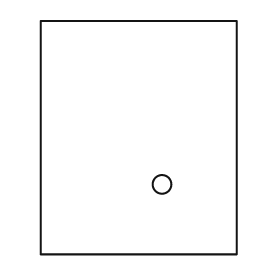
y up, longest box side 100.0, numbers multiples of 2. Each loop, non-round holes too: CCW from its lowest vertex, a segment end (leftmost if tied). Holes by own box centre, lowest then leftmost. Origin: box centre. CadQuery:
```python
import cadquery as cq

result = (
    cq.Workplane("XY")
    .moveTo(-42.0, -50.0)
    .lineTo(42.0, -50.0)
    .lineTo(42.0, 50.0)
    .lineTo(-42.0, 50.0)
    .close()
    .moveTo(10.0, -20.0)
    .circle(4.0)
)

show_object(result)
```